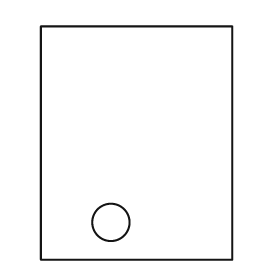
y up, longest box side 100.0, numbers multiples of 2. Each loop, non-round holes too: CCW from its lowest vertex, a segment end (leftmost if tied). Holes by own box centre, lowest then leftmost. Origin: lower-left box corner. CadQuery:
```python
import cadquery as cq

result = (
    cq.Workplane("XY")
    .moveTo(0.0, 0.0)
    .lineTo(82.0, 0.0)
    .lineTo(82.0, 100.0)
    .lineTo(0.0, 100.0)
    .close()
    .moveTo(30.0, 16.0)
    .circle(8.0)
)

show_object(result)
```